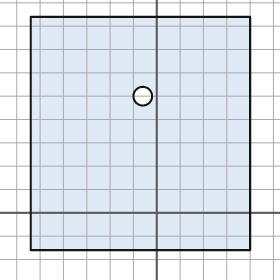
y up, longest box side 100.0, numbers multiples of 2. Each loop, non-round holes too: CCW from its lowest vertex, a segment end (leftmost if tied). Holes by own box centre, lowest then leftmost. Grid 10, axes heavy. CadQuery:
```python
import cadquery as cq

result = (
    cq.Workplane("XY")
    .moveTo(-54.0, -16.0)
    .lineTo(40.0, -16.0)
    .lineTo(40.0, 84.0)
    .lineTo(-54.0, 84.0)
    .close()
    .moveTo(-6.0, 50.0)
    .circle(4.0)
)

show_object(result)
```